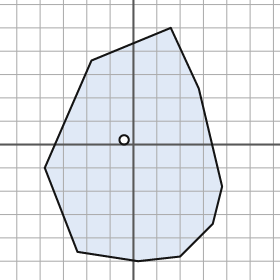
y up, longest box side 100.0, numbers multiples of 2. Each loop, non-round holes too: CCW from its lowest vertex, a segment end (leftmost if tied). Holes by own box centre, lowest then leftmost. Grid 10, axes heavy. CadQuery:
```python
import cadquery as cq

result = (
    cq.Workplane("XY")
    .moveTo(2.0, -50.0)
    .lineTo(20.0, -48.0)
    .lineTo(34.0, -34.0)
    .lineTo(38.0, -18.0)
    .lineTo(28.0, 24.0)
    .lineTo(16.0, 50.0)
    .lineTo(-18.0, 36.0)
    .lineTo(-38.0, -10.0)
    .lineTo(-24.0, -46.0)
    .close()
    .moveTo(-4.0, 2.0)
    .circle(2.0)
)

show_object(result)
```